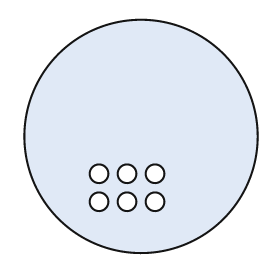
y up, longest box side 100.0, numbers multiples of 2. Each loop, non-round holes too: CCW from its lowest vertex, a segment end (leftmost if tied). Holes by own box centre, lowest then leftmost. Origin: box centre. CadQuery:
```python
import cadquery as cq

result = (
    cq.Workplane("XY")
    .moveTo(0.0, 0.0)
    .circle(50.0)
    .moveTo(-18.0, -28.0)
    .circle(4.0)
    .moveTo(-6.0, -28.0)
    .circle(4.0)
    .moveTo(6.0, -28.0)
    .circle(4.0)
    .moveTo(-18.0, -16.0)
    .circle(4.0)
    .moveTo(-6.0, -16.0)
    .circle(4.0)
    .moveTo(6.0, -16.0)
    .circle(4.0)
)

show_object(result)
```